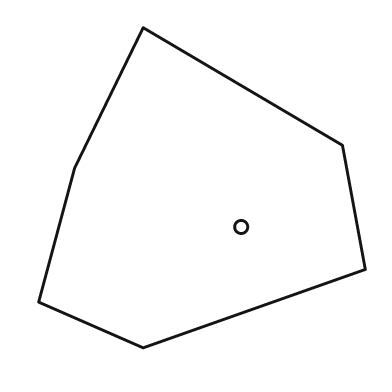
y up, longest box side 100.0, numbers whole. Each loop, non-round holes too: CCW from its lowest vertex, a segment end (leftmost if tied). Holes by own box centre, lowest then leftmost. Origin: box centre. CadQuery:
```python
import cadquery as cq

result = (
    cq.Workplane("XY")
    .moveTo(-18.0, -49.0)
    .lineTo(50.0, -25.0)
    .lineTo(43.0, 13.0)
    .lineTo(-18.0, 49.0)
    .lineTo(-39.0, 6.0)
    .lineTo(-50.0, -35.0)
    .close()
    .moveTo(12.0, -12.0)
    .circle(2.0)
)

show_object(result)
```